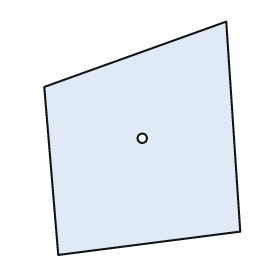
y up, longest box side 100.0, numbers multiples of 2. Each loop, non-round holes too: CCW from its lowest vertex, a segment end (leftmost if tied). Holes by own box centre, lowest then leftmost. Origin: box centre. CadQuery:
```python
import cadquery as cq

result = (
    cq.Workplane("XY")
    .moveTo(-36.0, -50.0)
    .lineTo(42.0, -40.0)
    .lineTo(36.0, 50.0)
    .lineTo(-42.0, 22.0)
    .close()
    .moveTo(0.0, 0.0)
    .circle(2.0)
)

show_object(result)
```